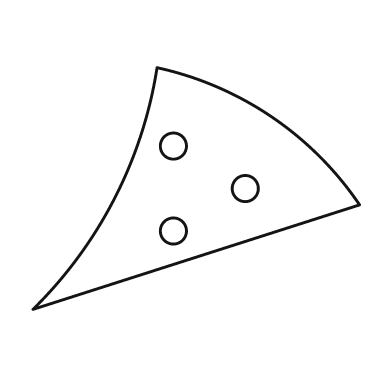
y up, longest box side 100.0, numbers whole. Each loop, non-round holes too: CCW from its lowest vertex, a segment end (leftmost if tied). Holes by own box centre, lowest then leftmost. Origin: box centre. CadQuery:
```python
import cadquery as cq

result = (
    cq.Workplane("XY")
    .moveTo(-50.0, -37.0)
    .lineTo(50.0, -5.0)
    .threePointArc((23.0, 22.0), (-12.0, 37.0))
    .threePointArc((-25.0, -3.0), (-50.0, -37.0))
    .close()
    .moveTo(-7.0, -13.0)
    .circle(4.0)
    .moveTo(15.0, 0.0)
    .circle(4.0)
    .moveTo(-7.0, 13.0)
    .circle(4.0)
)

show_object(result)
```